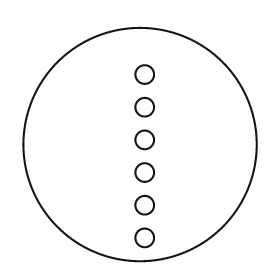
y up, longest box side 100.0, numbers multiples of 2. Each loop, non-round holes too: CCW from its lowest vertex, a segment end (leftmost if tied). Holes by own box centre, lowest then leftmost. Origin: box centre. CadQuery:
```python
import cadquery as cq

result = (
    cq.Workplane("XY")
    .moveTo(0.0, 0.0)
    .circle(50.0)
    .moveTo(2.0, -40.0)
    .circle(4.0)
    .moveTo(2.0, -26.0)
    .circle(4.0)
    .moveTo(2.0, -12.0)
    .circle(4.0)
    .moveTo(2.0, 2.0)
    .circle(4.0)
    .moveTo(2.0, 16.0)
    .circle(4.0)
    .moveTo(2.0, 30.0)
    .circle(4.0)
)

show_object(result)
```